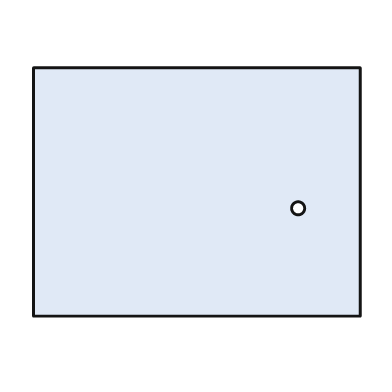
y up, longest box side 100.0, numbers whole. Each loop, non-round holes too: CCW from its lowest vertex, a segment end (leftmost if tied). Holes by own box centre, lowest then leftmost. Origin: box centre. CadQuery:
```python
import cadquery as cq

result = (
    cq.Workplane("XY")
    .moveTo(-50.0, -38.0)
    .lineTo(50.0, -38.0)
    .lineTo(50.0, 38.0)
    .lineTo(-50.0, 38.0)
    .close()
    .moveTo(31.0, -5.0)
    .circle(2.0)
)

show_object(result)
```